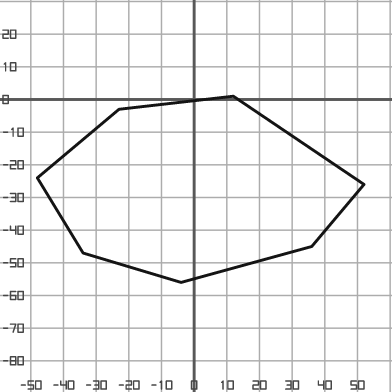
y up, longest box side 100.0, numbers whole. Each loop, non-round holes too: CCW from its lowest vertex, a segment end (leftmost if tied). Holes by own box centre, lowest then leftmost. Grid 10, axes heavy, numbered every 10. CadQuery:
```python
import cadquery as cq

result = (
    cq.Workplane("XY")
    .moveTo(-4.0, -56.0)
    .lineTo(36.0, -45.0)
    .lineTo(52.0, -26.0)
    .lineTo(12.0, 1.0)
    .lineTo(-23.0, -3.0)
    .lineTo(-48.0, -24.0)
    .lineTo(-34.0, -47.0)
    .close()
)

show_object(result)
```